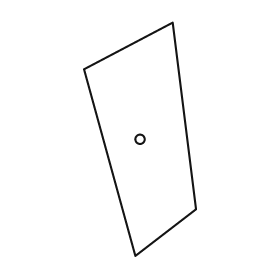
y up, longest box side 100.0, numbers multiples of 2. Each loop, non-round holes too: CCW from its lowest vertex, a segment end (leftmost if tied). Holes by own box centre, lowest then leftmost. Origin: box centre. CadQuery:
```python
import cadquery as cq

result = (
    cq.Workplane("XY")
    .moveTo(-2.0, -50.0)
    .lineTo(24.0, -30.0)
    .lineTo(14.0, 50.0)
    .lineTo(-24.0, 30.0)
    .close()
    .moveTo(0.0, 0.0)
    .circle(2.0)
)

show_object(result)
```